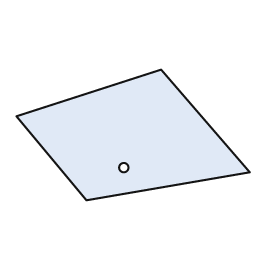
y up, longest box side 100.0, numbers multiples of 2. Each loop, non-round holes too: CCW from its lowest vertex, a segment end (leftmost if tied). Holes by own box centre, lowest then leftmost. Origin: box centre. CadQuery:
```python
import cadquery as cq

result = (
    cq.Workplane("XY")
    .moveTo(-20.0, -28.0)
    .lineTo(50.0, -16.0)
    .lineTo(12.0, 28.0)
    .lineTo(-50.0, 8.0)
    .close()
    .moveTo(-4.0, -14.0)
    .circle(2.0)
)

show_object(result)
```